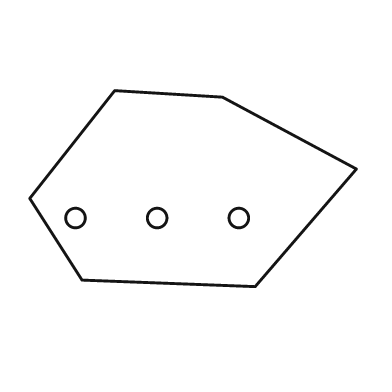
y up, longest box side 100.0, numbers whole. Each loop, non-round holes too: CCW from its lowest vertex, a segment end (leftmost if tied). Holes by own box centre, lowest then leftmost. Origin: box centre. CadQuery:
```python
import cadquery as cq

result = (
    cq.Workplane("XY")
    .moveTo(19.0, -30.0)
    .lineTo(50.0, 6.0)
    .lineTo(9.0, 28.0)
    .lineTo(-24.0, 30.0)
    .lineTo(-50.0, -3.0)
    .lineTo(-34.0, -28.0)
    .close()
    .moveTo(-36.0, -9.0)
    .circle(3.0)
    .moveTo(-11.0, -9.0)
    .circle(3.0)
    .moveTo(14.0, -9.0)
    .circle(3.0)
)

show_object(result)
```